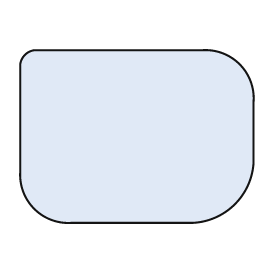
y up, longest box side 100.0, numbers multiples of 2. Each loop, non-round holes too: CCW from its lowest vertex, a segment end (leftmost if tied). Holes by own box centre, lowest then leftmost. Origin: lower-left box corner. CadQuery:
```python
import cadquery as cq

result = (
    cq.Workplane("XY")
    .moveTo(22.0, 0.0)
    .lineTo(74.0, 0.0)
    .threePointArc((92.0, 8.0), (100.0, 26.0))
    .lineTo(100.0, 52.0)
    .threePointArc((94.0, 68.0), (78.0, 74.0))
    .lineTo(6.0, 74.0)
    .threePointArc((2.0, 72.0), (0.0, 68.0))
    .lineTo(0.0, 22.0)
    .threePointArc((6.0, 6.0), (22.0, 0.0))
    .close()
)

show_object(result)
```